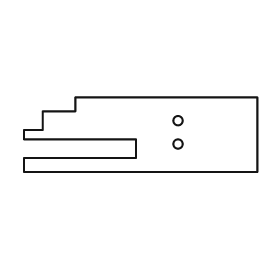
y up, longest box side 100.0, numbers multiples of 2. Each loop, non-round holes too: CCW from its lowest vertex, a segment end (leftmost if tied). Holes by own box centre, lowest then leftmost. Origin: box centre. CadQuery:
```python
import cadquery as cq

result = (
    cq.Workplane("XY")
    .moveTo(-50.0, -16.0)
    .lineTo(50.0, -16.0)
    .lineTo(50.0, 16.0)
    .lineTo(-28.0, 16.0)
    .lineTo(-28.0, 10.0)
    .lineTo(-42.0, 10.0)
    .lineTo(-42.0, 2.0)
    .lineTo(-50.0, 2.0)
    .lineTo(-50.0, -2.0)
    .lineTo(-2.0, -2.0)
    .lineTo(-2.0, -10.0)
    .lineTo(-50.0, -10.0)
    .close()
    .moveTo(16.0, -4.0)
    .circle(2.0)
    .moveTo(16.0, 6.0)
    .circle(2.0)
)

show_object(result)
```